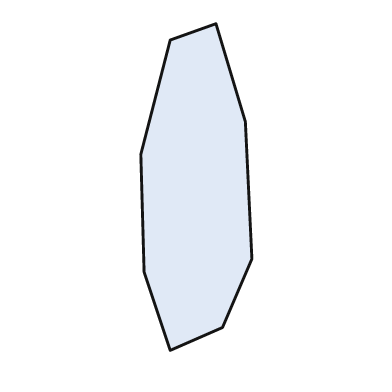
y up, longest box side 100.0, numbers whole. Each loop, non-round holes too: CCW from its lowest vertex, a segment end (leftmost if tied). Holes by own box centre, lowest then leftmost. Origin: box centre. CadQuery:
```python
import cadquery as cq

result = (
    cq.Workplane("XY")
    .moveTo(-8.0, -50.0)
    .lineTo(8.0, -43.0)
    .lineTo(17.0, -22.0)
    .lineTo(15.0, 20.0)
    .lineTo(6.0, 50.0)
    .lineTo(-8.0, 45.0)
    .lineTo(-17.0, 10.0)
    .lineTo(-16.0, -26.0)
    .close()
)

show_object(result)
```